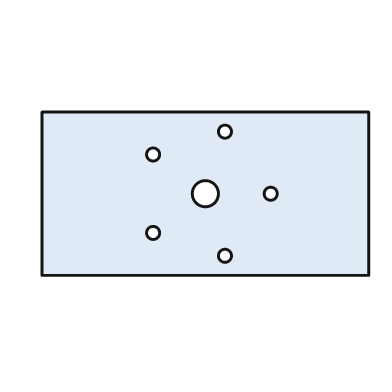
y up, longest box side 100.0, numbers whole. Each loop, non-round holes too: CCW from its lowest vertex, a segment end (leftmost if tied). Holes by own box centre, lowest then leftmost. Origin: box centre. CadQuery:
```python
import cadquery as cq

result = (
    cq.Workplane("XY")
    .moveTo(-50.0, -25.0)
    .lineTo(50.0, -25.0)
    .lineTo(50.0, 25.0)
    .lineTo(-50.0, 25.0)
    .close()
    .moveTo(6.0, -19.0)
    .circle(2.0)
    .moveTo(-16.0, -12.0)
    .circle(2.0)
    .moveTo(0.0, 0.0)
    .circle(4.0)
    .moveTo(20.0, 0.0)
    .circle(2.0)
    .moveTo(-16.0, 12.0)
    .circle(2.0)
    .moveTo(6.0, 19.0)
    .circle(2.0)
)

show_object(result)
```